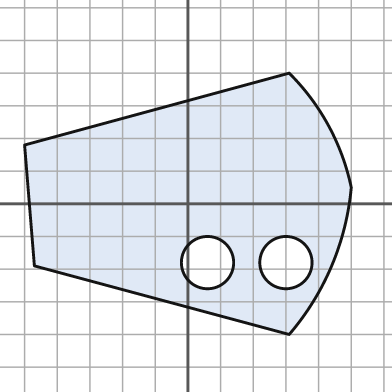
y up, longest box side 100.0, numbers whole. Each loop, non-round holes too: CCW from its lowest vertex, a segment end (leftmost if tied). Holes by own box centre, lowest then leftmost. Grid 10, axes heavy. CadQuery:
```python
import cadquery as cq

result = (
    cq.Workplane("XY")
    .moveTo(31.0, -40.0)
    .threePointArc((44.0, -19.0), (50.0, 5.0))
    .threePointArc((43.0, 24.0), (31.0, 40.0))
    .lineTo(-50.0, 18.0)
    .lineTo(-47.0, -19.0)
    .close()
    .moveTo(6.0, -18.0)
    .circle(8.0)
    .moveTo(30.0, -18.0)
    .circle(8.0)
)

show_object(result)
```